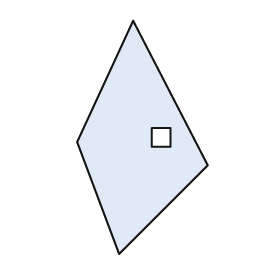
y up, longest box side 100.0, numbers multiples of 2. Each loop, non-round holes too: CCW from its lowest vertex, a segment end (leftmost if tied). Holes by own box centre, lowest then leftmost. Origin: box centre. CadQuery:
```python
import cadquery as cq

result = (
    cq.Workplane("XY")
    .moveTo(-10.0, -50.0)
    .lineTo(28.0, -12.0)
    .lineTo(-4.0, 50.0)
    .lineTo(-28.0, -2.0)
    .close()
    .moveTo(4.0, -4.0)
    .lineTo(12.0, -4.0)
    .lineTo(12.0, 4.0)
    .lineTo(4.0, 4.0)
    .close()
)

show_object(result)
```